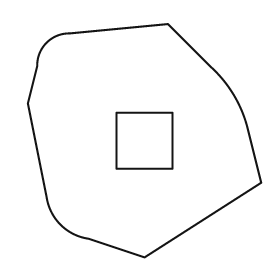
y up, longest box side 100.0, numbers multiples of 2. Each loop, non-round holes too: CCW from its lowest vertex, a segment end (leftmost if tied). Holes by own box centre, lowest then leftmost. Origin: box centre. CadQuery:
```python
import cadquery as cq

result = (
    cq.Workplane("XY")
    .moveTo(0.0, -50.0)
    .lineTo(50.0, -18.0)
    .lineTo(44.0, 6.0)
    .threePointArc((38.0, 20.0), (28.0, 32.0))
    .lineTo(10.0, 50.0)
    .lineTo(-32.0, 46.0)
    .threePointArc((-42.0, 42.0), (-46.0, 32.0))
    .lineTo(-50.0, 16.0)
    .lineTo(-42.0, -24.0)
    .threePointArc((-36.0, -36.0), (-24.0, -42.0))
    .close()
    .moveTo(-12.0, -12.0)
    .lineTo(12.0, -12.0)
    .lineTo(12.0, 12.0)
    .lineTo(-12.0, 12.0)
    .close()
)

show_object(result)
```